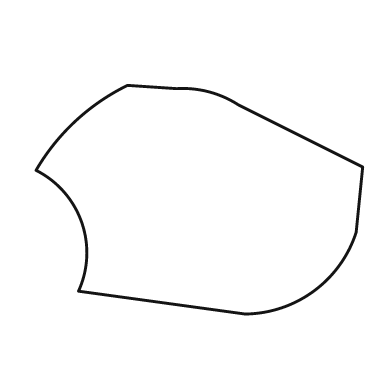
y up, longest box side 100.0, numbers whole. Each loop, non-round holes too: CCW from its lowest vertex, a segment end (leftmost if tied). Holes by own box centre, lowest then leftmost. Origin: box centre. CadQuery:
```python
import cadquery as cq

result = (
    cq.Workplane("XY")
    .moveTo(14.0, -35.0)
    .threePointArc((35.0, -28.0), (48.0, -10.0))
    .lineTo(50.0, 10.0)
    .lineTo(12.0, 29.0)
    .threePointArc((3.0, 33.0), (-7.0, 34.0))
    .lineTo(-22.0, 35.0)
    .threePointArc((-38.0, 24.0), (-50.0, 9.0))
    .threePointArc((-36.0, -7.0), (-37.0, -28.0))
    .close()
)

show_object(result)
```